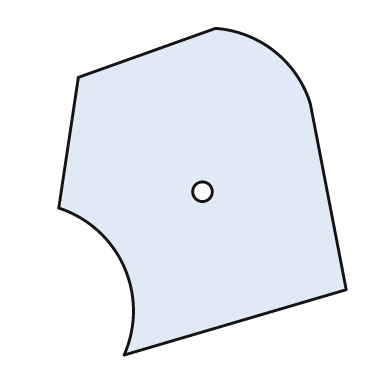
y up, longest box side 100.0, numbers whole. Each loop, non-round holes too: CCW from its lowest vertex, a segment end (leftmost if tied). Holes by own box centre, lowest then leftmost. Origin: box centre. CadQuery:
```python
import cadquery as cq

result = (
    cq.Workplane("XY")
    .moveTo(-24.0, -50.0)
    .lineTo(44.0, -30.0)
    .lineTo(33.0, 27.0)
    .threePointArc((22.0, 43.0), (4.0, 50.0))
    .lineTo(-38.0, 35.0)
    .lineTo(-44.0, -5.0)
    .threePointArc((-24.0, -23.0), (-24.0, -50.0))
    .close()
    .moveTo(0.0, 0.0)
    .circle(3.0)
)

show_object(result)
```